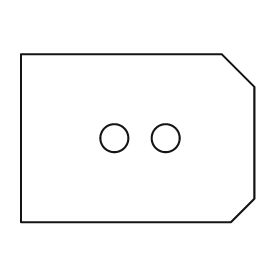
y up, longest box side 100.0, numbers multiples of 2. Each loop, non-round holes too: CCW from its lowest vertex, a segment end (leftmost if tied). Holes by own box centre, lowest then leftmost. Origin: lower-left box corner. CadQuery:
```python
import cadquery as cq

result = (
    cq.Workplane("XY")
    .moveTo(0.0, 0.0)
    .lineTo(90.0, 0.0)
    .lineTo(100.0, 10.0)
    .lineTo(100.0, 58.0)
    .lineTo(86.0, 72.0)
    .lineTo(0.0, 72.0)
    .close()
    .moveTo(40.0, 36.0)
    .circle(6.0)
    .moveTo(62.0, 36.0)
    .circle(6.0)
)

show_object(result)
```